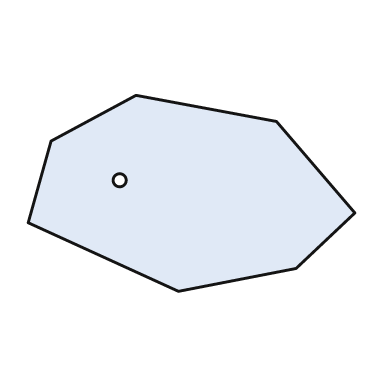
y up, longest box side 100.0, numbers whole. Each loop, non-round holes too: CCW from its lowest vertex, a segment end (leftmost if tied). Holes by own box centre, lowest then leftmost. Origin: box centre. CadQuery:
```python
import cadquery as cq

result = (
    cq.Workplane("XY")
    .moveTo(-4.0, -30.0)
    .lineTo(32.0, -23.0)
    .lineTo(50.0, -6.0)
    .lineTo(26.0, 22.0)
    .lineTo(-17.0, 30.0)
    .lineTo(-43.0, 16.0)
    .lineTo(-50.0, -9.0)
    .close()
    .moveTo(-22.0, 4.0)
    .circle(2.0)
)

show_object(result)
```